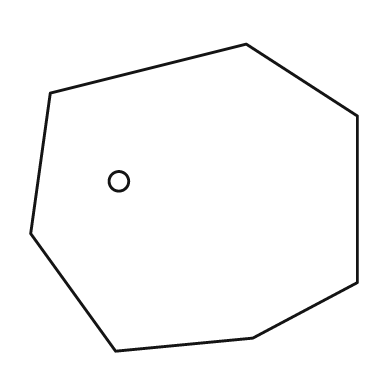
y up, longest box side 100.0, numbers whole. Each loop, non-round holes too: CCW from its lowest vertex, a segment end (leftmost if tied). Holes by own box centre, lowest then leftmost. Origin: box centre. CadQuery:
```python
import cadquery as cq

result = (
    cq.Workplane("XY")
    .moveTo(-24.0, -47.0)
    .lineTo(18.0, -43.0)
    .lineTo(50.0, -26.0)
    .lineTo(50.0, 25.0)
    .lineTo(16.0, 47.0)
    .lineTo(-44.0, 32.0)
    .lineTo(-50.0, -11.0)
    .close()
    .moveTo(-23.0, 5.0)
    .circle(3.0)
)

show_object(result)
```